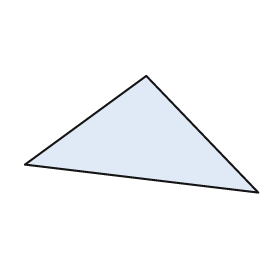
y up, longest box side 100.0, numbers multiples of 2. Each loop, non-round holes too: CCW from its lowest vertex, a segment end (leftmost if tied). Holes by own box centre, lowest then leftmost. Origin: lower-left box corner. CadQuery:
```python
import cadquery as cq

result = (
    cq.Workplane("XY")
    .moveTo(100.0, 0.0)
    .lineTo(52.0, 50.0)
    .lineTo(0.0, 12.0)
    .close()
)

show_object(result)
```